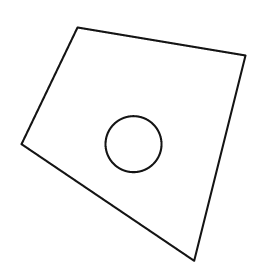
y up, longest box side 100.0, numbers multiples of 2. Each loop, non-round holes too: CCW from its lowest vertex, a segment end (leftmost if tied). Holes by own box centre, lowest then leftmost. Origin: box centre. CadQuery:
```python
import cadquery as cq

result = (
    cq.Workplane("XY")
    .moveTo(26.0, -50.0)
    .lineTo(48.0, 38.0)
    .lineTo(-24.0, 50.0)
    .lineTo(-48.0, 0.0)
    .close()
    .moveTo(0.0, 0.0)
    .circle(12.0)
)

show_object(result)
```